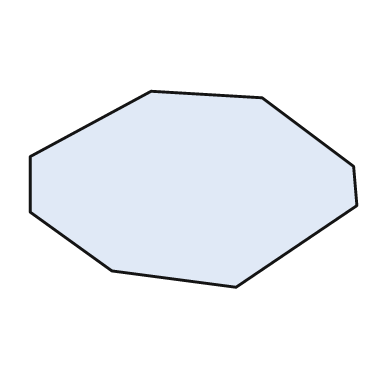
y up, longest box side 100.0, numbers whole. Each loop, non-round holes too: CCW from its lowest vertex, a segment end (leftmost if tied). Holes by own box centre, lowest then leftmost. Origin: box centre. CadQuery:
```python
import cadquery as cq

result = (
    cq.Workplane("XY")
    .moveTo(13.0, -30.0)
    .lineTo(50.0, -5.0)
    .lineTo(49.0, 7.0)
    .lineTo(21.0, 28.0)
    .lineTo(-13.0, 30.0)
    .lineTo(-50.0, 10.0)
    .lineTo(-50.0, -7.0)
    .lineTo(-25.0, -25.0)
    .close()
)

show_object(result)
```